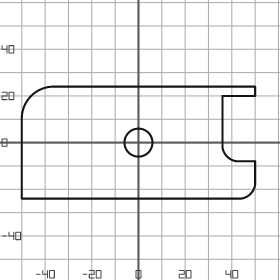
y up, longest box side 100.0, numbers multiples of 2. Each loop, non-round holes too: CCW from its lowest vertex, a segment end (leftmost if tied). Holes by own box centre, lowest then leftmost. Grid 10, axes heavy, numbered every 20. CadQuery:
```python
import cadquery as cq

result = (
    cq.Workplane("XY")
    .moveTo(-50.0, -24.0)
    .lineTo(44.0, -24.0)
    .threePointArc((48.0, -22.0), (50.0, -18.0))
    .lineTo(50.0, -8.0)
    .lineTo(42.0, -8.0)
    .threePointArc((38.0, -6.0), (36.0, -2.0))
    .lineTo(36.0, 20.0)
    .lineTo(50.0, 20.0)
    .lineTo(50.0, 24.0)
    .lineTo(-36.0, 24.0)
    .threePointArc((-46.0, 20.0), (-50.0, 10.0))
    .close()
    .moveTo(0.0, 0.0)
    .circle(6.0)
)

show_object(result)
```